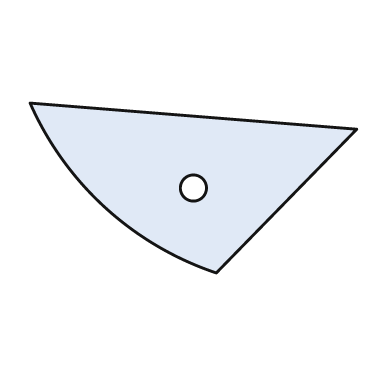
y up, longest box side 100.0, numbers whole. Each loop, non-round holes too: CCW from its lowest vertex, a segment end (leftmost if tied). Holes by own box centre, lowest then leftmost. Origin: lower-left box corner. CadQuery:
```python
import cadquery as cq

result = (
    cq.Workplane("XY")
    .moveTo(57.0, 0.0)
    .lineTo(100.0, 44.0)
    .lineTo(0.0, 52.0)
    .threePointArc((23.0, 20.0), (57.0, 0.0))
    .close()
    .moveTo(50.0, 26.0)
    .circle(4.0)
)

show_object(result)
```